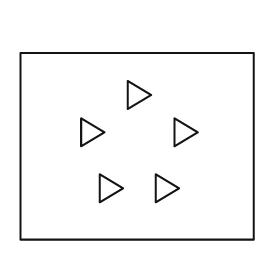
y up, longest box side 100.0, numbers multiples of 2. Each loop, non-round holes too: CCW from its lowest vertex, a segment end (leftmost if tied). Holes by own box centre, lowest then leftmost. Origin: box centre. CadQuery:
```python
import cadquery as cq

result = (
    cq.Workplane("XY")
    .moveTo(-50.0, -40.0)
    .lineTo(50.0, -40.0)
    .lineTo(50.0, 40.0)
    .lineTo(-50.0, 40.0)
    .close()
    .moveTo(-16.0, -24.0)
    .lineTo(-6.0, -18.0)
    .lineTo(-16.0, -12.0)
    .close()
    .moveTo(8.0, -24.0)
    .lineTo(18.0, -18.0)
    .lineTo(8.0, -12.0)
    .close()
    .moveTo(-24.0, 0.0)
    .lineTo(-14.0, 6.0)
    .lineTo(-24.0, 12.0)
    .close()
    .moveTo(16.0, 0.0)
    .lineTo(26.0, 6.0)
    .lineTo(16.0, 12.0)
    .close()
    .moveTo(-4.0, 16.0)
    .lineTo(6.0, 22.0)
    .lineTo(-4.0, 28.0)
    .close()
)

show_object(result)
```